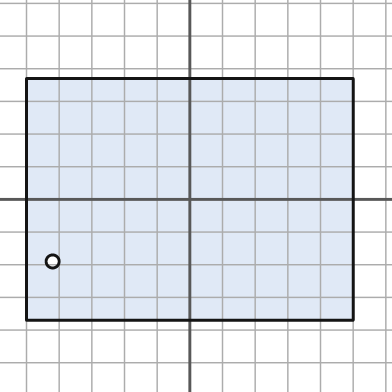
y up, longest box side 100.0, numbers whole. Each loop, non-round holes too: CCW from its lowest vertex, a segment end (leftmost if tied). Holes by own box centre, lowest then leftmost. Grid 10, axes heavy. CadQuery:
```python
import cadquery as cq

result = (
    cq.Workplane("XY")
    .moveTo(-50.0, -37.0)
    .lineTo(50.0, -37.0)
    .lineTo(50.0, 37.0)
    .lineTo(-50.0, 37.0)
    .close()
    .moveTo(-42.0, -19.0)
    .circle(2.0)
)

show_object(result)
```